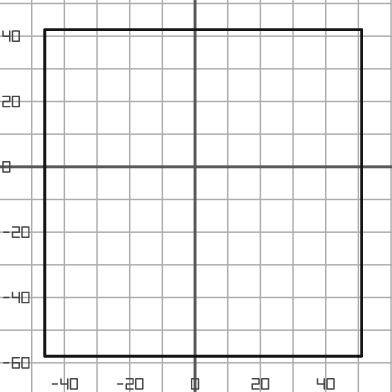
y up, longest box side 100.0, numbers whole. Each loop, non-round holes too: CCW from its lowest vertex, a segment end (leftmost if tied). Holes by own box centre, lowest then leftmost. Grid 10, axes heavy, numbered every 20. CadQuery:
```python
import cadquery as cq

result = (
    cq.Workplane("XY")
    .moveTo(-46.0, -58.0)
    .lineTo(51.0, -58.0)
    .lineTo(51.0, 42.0)
    .lineTo(-46.0, 42.0)
    .close()
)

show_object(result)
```